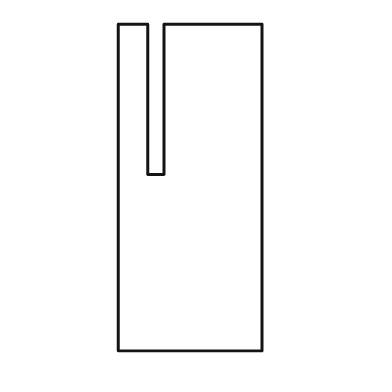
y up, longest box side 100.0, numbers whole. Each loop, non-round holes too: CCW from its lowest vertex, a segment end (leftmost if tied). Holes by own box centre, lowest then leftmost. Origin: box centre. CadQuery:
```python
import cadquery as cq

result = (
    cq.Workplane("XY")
    .moveTo(-22.0, -50.0)
    .lineTo(22.0, -50.0)
    .lineTo(22.0, 50.0)
    .lineTo(-8.0, 50.0)
    .lineTo(-8.0, 4.0)
    .lineTo(-13.0, 4.0)
    .lineTo(-13.0, 50.0)
    .lineTo(-22.0, 50.0)
    .close()
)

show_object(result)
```